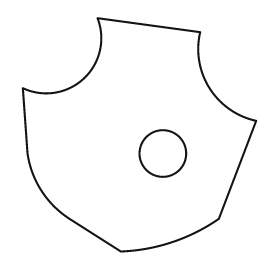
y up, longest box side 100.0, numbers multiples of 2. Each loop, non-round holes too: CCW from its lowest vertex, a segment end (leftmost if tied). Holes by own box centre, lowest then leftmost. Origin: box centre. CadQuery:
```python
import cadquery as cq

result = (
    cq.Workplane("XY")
    .moveTo(-8.0, -50.0)
    .threePointArc((14.0, -46.0), (34.0, -36.0))
    .lineTo(50.0, 6.0)
    .threePointArc((30.0, 20.0), (26.0, 44.0))
    .lineTo(-18.0, 50.0)
    .threePointArc((-24.0, 24.0), (-50.0, 20.0))
    .lineTo(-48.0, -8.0)
    .threePointArc((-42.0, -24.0), (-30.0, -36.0))
    .close()
    .moveTo(10.0, -8.0)
    .circle(10.0)
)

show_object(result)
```